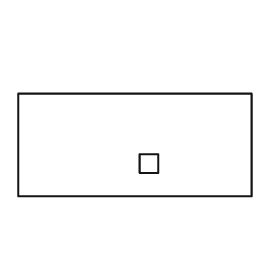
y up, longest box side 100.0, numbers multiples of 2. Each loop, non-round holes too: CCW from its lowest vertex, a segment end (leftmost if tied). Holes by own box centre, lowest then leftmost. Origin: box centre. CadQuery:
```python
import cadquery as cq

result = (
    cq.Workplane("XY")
    .moveTo(-50.0, -22.0)
    .lineTo(50.0, -22.0)
    .lineTo(50.0, 22.0)
    .lineTo(-50.0, 22.0)
    .close()
    .moveTo(2.0, -12.0)
    .lineTo(10.0, -12.0)
    .lineTo(10.0, -4.0)
    .lineTo(2.0, -4.0)
    .close()
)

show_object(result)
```